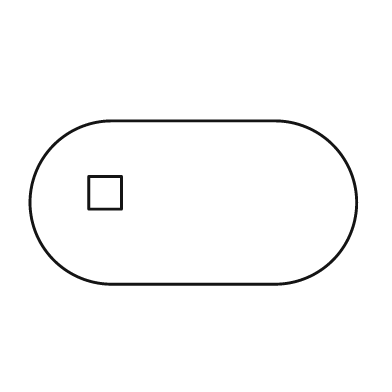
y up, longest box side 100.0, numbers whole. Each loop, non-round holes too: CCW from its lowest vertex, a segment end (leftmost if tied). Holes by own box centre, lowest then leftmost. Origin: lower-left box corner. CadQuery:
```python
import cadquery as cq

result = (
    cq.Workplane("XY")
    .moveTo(25.0, 0.0)
    .lineTo(75.0, 0.0)
    .threePointArc((100.0, 25.0), (75.0, 50.0))
    .lineTo(25.0, 50.0)
    .threePointArc((0.0, 25.0), (25.0, 0.0))
    .close()
    .moveTo(18.0, 23.0)
    .lineTo(28.0, 23.0)
    .lineTo(28.0, 33.0)
    .lineTo(18.0, 33.0)
    .close()
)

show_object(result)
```